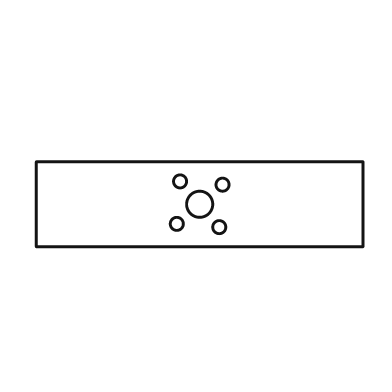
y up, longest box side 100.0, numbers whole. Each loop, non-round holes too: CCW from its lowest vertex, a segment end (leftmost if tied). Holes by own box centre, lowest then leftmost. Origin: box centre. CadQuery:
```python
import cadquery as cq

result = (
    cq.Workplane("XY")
    .moveTo(-50.0, -13.0)
    .lineTo(50.0, -13.0)
    .lineTo(50.0, 13.0)
    .lineTo(-50.0, 13.0)
    .close()
    .moveTo(6.0, -7.0)
    .circle(2.0)
    .moveTo(-7.0, -6.0)
    .circle(2.0)
    .moveTo(0.0, 0.0)
    .circle(4.0)
    .moveTo(7.0, 6.0)
    .circle(2.0)
    .moveTo(-6.0, 7.0)
    .circle(2.0)
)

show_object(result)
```